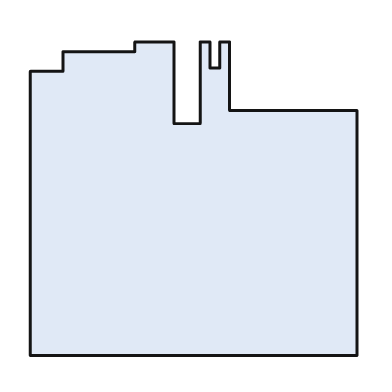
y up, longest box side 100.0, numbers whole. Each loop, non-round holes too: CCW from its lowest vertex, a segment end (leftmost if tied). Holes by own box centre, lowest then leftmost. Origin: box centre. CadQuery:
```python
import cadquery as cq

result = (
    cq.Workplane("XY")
    .moveTo(-50.0, -48.0)
    .lineTo(50.0, -48.0)
    .lineTo(50.0, 27.0)
    .lineTo(11.0, 27.0)
    .lineTo(11.0, 48.0)
    .lineTo(8.0, 48.0)
    .lineTo(8.0, 40.0)
    .lineTo(5.0, 40.0)
    .lineTo(5.0, 48.0)
    .lineTo(2.0, 48.0)
    .lineTo(2.0, 23.0)
    .lineTo(-6.0, 23.0)
    .lineTo(-6.0, 48.0)
    .lineTo(-18.0, 48.0)
    .lineTo(-18.0, 45.0)
    .lineTo(-40.0, 45.0)
    .lineTo(-40.0, 39.0)
    .lineTo(-50.0, 39.0)
    .close()
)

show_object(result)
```